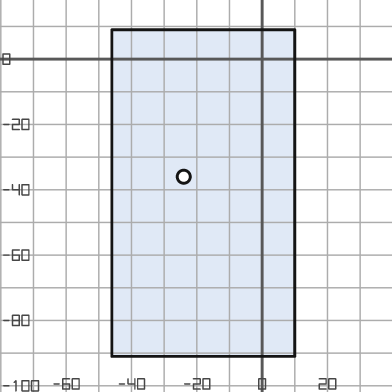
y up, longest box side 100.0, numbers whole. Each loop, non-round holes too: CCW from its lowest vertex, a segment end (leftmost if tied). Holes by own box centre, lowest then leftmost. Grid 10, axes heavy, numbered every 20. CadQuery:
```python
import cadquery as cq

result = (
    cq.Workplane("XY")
    .moveTo(-46.0, -91.0)
    .lineTo(10.0, -91.0)
    .lineTo(10.0, 9.0)
    .lineTo(-46.0, 9.0)
    .close()
    .moveTo(-24.0, -36.0)
    .circle(2.0)
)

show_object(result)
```